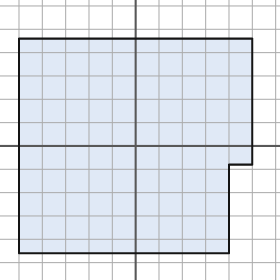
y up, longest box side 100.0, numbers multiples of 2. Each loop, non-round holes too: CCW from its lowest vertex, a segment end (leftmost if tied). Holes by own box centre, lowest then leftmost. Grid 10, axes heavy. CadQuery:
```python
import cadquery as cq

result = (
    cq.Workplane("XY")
    .moveTo(-50.0, -46.0)
    .lineTo(40.0, -46.0)
    .lineTo(40.0, -8.0)
    .lineTo(50.0, -8.0)
    .lineTo(50.0, 46.0)
    .lineTo(-50.0, 46.0)
    .close()
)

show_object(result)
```